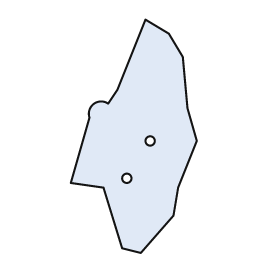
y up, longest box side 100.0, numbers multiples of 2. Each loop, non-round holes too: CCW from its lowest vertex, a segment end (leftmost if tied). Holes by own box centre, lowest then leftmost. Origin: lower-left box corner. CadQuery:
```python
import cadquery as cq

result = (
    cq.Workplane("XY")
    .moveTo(30.0, 0.0)
    .lineTo(44.0, 16.0)
    .lineTo(46.0, 28.0)
    .lineTo(54.0, 48.0)
    .lineTo(50.0, 62.0)
    .lineTo(48.0, 84.0)
    .lineTo(42.0, 94.0)
    .lineTo(32.0, 100.0)
    .lineTo(20.0, 70.0)
    .lineTo(16.0, 64.0)
    .threePointArc((10.0, 64.0), (8.0, 58.0))
    .lineTo(0.0, 30.0)
    .lineTo(14.0, 28.0)
    .lineTo(22.0, 2.0)
    .close()
    .moveTo(24.0, 32.0)
    .circle(2.0)
    .moveTo(34.0, 48.0)
    .circle(2.0)
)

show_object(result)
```